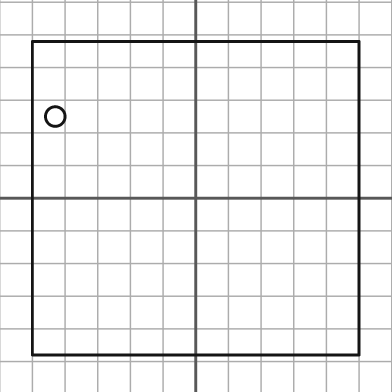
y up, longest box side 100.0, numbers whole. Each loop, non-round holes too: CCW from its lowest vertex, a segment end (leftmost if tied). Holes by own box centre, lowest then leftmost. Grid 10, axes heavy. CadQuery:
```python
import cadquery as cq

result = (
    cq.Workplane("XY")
    .moveTo(-50.0, -48.0)
    .lineTo(50.0, -48.0)
    .lineTo(50.0, 48.0)
    .lineTo(-50.0, 48.0)
    .close()
    .moveTo(-43.0, 25.0)
    .circle(3.0)
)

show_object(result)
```